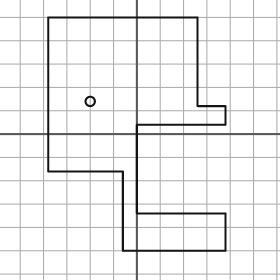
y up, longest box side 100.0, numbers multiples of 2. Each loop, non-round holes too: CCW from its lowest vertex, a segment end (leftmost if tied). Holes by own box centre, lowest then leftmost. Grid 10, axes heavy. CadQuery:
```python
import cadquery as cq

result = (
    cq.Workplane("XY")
    .moveTo(-6.0, -50.0)
    .lineTo(38.0, -50.0)
    .lineTo(38.0, -34.0)
    .lineTo(0.0, -34.0)
    .lineTo(0.0, 4.0)
    .lineTo(38.0, 4.0)
    .lineTo(38.0, 12.0)
    .lineTo(26.0, 12.0)
    .lineTo(26.0, 50.0)
    .lineTo(-38.0, 50.0)
    .lineTo(-38.0, -16.0)
    .lineTo(-6.0, -16.0)
    .close()
    .moveTo(-20.0, 14.0)
    .circle(2.0)
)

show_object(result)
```